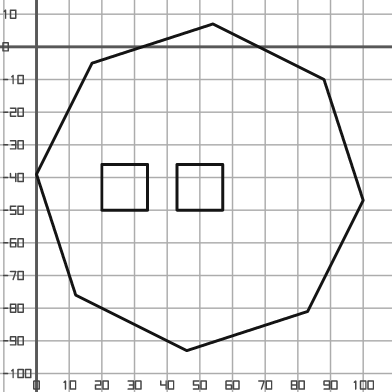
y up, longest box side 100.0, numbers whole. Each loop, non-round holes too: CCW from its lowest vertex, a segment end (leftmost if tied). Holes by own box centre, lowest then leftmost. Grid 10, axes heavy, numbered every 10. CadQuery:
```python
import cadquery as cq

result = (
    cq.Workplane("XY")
    .moveTo(46.0, -93.0)
    .lineTo(83.0, -81.0)
    .lineTo(100.0, -47.0)
    .lineTo(88.0, -10.0)
    .lineTo(54.0, 7.0)
    .lineTo(17.0, -5.0)
    .lineTo(0.0, -39.0)
    .lineTo(12.0, -76.0)
    .close()
    .moveTo(20.0, -50.0)
    .lineTo(34.0, -50.0)
    .lineTo(34.0, -36.0)
    .lineTo(20.0, -36.0)
    .close()
    .moveTo(43.0, -50.0)
    .lineTo(57.0, -50.0)
    .lineTo(57.0, -36.0)
    .lineTo(43.0, -36.0)
    .close()
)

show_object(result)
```